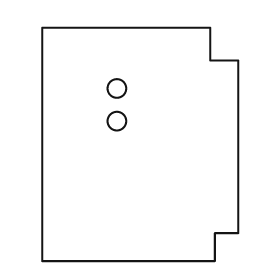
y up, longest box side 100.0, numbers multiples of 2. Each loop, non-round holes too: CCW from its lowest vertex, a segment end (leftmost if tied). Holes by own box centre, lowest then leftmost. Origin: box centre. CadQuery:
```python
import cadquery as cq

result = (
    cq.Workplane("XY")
    .moveTo(-42.0, -50.0)
    .lineTo(32.0, -50.0)
    .lineTo(32.0, -38.0)
    .lineTo(42.0, -38.0)
    .lineTo(42.0, 36.0)
    .lineTo(30.0, 36.0)
    .lineTo(30.0, 50.0)
    .lineTo(-42.0, 50.0)
    .close()
    .moveTo(-10.0, 10.0)
    .circle(4.0)
    .moveTo(-10.0, 24.0)
    .circle(4.0)
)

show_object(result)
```